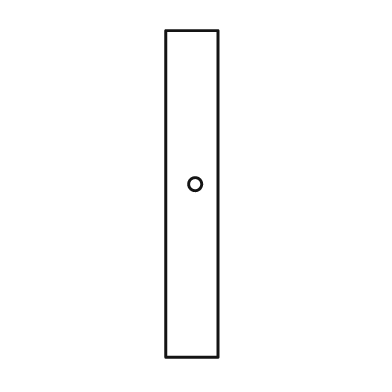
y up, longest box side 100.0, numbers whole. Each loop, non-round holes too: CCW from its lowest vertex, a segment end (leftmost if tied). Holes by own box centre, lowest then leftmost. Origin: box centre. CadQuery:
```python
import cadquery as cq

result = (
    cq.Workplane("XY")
    .moveTo(-8.0, -50.0)
    .lineTo(8.0, -50.0)
    .lineTo(8.0, 50.0)
    .lineTo(-8.0, 50.0)
    .close()
    .moveTo(1.0, 3.0)
    .circle(2.0)
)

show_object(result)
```